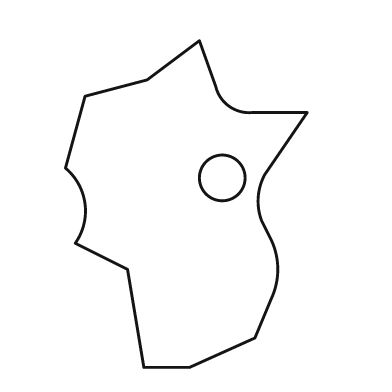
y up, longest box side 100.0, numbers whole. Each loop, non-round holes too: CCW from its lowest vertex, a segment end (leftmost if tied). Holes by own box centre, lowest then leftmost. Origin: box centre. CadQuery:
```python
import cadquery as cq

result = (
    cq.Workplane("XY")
    .moveTo(-13.0, -50.0)
    .lineTo(1.0, -50.0)
    .lineTo(21.0, -41.0)
    .lineTo(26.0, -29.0)
    .threePointArc((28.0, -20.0), (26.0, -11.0))
    .lineTo(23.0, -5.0)
    .threePointArc((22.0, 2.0), (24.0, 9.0))
    .lineTo(37.0, 28.0)
    .lineTo(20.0, 28.0)
    .threePointArc((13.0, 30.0), (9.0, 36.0))
    .lineTo(4.0, 50.0)
    .lineTo(-12.0, 38.0)
    .lineTo(-31.0, 33.0)
    .lineTo(-37.0, 11.0)
    .threePointArc((-31.0, 0.0), (-34.0, -12.0))
    .lineTo(-18.0, -20.0)
    .close()
    .moveTo(11.0, 8.0)
    .circle(7.0)
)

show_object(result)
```